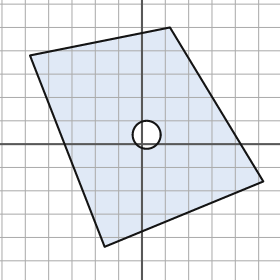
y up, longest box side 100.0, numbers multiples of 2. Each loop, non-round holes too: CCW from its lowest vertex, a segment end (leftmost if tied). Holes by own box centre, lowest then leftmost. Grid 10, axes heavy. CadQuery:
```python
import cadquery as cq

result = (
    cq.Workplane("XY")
    .moveTo(-16.0, -44.0)
    .lineTo(52.0, -16.0)
    .lineTo(12.0, 50.0)
    .lineTo(-48.0, 38.0)
    .close()
    .moveTo(2.0, 4.0)
    .circle(6.0)
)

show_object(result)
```